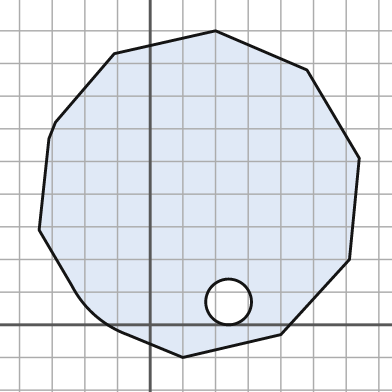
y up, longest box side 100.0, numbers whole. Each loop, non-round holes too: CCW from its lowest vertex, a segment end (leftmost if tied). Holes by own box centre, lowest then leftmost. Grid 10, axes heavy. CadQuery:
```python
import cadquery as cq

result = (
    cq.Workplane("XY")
    .moveTo(10.0, -10.0)
    .lineTo(40.0, -3.0)
    .lineTo(61.0, 20.0)
    .lineTo(64.0, 51.0)
    .lineTo(48.0, 78.0)
    .lineTo(20.0, 90.0)
    .lineTo(-11.0, 83.0)
    .lineTo(-29.0, 62.0)
    .lineTo(-31.0, 57.0)
    .lineTo(-34.0, 29.0)
    .lineTo(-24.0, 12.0)
    .threePointArc((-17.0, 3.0), (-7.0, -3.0))
    .close()
    .moveTo(24.0, 7.0)
    .circle(7.0)
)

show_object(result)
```